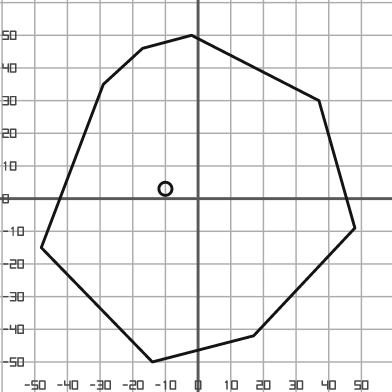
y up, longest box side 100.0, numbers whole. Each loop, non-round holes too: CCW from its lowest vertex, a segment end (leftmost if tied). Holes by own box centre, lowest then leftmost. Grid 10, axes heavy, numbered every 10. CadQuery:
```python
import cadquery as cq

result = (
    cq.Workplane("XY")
    .moveTo(-14.0, -50.0)
    .lineTo(17.0, -42.0)
    .lineTo(48.0, -9.0)
    .lineTo(37.0, 30.0)
    .lineTo(-2.0, 50.0)
    .lineTo(-17.0, 46.0)
    .lineTo(-29.0, 35.0)
    .lineTo(-48.0, -15.0)
    .close()
    .moveTo(-10.0, 3.0)
    .circle(2.0)
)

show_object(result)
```